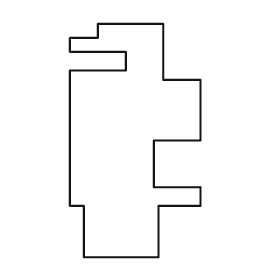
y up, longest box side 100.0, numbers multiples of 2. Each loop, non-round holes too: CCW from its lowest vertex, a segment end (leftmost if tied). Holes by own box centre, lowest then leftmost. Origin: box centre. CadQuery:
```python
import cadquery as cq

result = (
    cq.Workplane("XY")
    .moveTo(-22.0, -50.0)
    .lineTo(10.0, -50.0)
    .lineTo(10.0, -28.0)
    .lineTo(28.0, -28.0)
    .lineTo(28.0, -20.0)
    .lineTo(8.0, -20.0)
    .lineTo(8.0, 0.0)
    .lineTo(28.0, 0.0)
    .lineTo(28.0, 26.0)
    .lineTo(12.0, 26.0)
    .lineTo(12.0, 50.0)
    .lineTo(-16.0, 50.0)
    .lineTo(-16.0, 44.0)
    .lineTo(-28.0, 44.0)
    .lineTo(-28.0, 38.0)
    .lineTo(-4.0, 38.0)
    .lineTo(-4.0, 30.0)
    .lineTo(-28.0, 30.0)
    .lineTo(-28.0, -28.0)
    .lineTo(-22.0, -28.0)
    .close()
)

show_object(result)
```